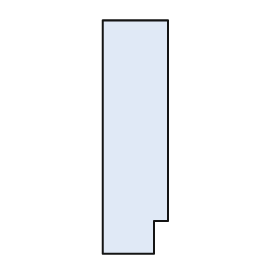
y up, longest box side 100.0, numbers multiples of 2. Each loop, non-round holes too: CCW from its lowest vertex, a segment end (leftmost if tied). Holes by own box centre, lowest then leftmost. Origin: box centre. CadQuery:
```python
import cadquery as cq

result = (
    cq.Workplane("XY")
    .moveTo(-14.0, -50.0)
    .lineTo(8.0, -50.0)
    .lineTo(8.0, -36.0)
    .lineTo(14.0, -36.0)
    .lineTo(14.0, 50.0)
    .lineTo(-14.0, 50.0)
    .close()
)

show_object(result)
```